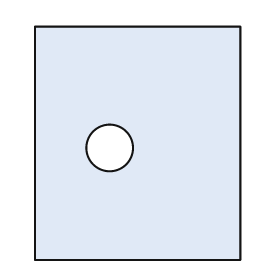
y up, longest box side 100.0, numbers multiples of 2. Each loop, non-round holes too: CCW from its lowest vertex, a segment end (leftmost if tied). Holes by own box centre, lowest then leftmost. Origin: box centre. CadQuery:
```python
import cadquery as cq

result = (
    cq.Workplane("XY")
    .moveTo(-44.0, -50.0)
    .lineTo(44.0, -50.0)
    .lineTo(44.0, 50.0)
    .lineTo(-44.0, 50.0)
    .close()
    .moveTo(-12.0, -2.0)
    .circle(10.0)
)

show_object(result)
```